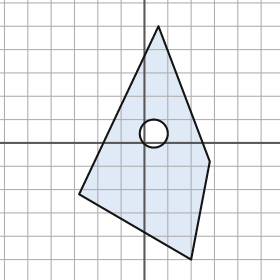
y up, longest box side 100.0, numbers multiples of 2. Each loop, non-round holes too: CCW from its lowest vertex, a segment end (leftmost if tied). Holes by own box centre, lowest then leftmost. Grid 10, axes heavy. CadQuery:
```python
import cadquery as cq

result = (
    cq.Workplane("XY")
    .moveTo(20.0, -50.0)
    .lineTo(28.0, -8.0)
    .lineTo(6.0, 50.0)
    .lineTo(-28.0, -22.0)
    .close()
    .moveTo(4.0, 4.0)
    .circle(6.0)
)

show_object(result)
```